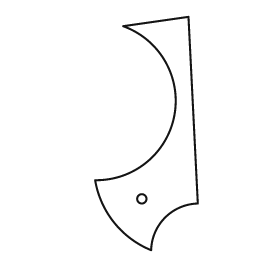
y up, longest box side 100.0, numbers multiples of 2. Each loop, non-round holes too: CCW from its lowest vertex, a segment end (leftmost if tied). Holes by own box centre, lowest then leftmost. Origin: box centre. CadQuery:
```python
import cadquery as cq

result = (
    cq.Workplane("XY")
    .moveTo(2.0, -50.0)
    .threePointArc((8.0, -36.0), (22.0, -30.0))
    .lineTo(18.0, 50.0)
    .lineTo(-10.0, 46.0)
    .threePointArc((12.0, 8.0), (-22.0, -20.0))
    .threePointArc((-14.0, -38.0), (2.0, -50.0))
    .close()
    .moveTo(-2.0, -28.0)
    .circle(2.0)
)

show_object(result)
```